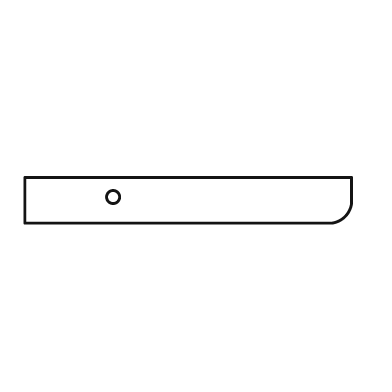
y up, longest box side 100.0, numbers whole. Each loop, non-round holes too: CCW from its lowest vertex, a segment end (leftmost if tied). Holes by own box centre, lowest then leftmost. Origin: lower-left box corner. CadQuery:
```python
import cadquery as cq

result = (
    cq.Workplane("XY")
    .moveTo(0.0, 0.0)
    .lineTo(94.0, 0.0)
    .threePointArc((98.0, 2.0), (100.0, 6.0))
    .lineTo(100.0, 14.0)
    .lineTo(0.0, 14.0)
    .close()
    .moveTo(27.0, 8.0)
    .circle(2.0)
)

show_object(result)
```